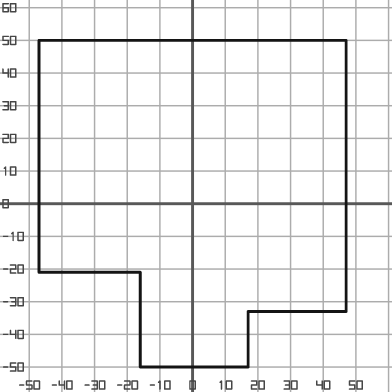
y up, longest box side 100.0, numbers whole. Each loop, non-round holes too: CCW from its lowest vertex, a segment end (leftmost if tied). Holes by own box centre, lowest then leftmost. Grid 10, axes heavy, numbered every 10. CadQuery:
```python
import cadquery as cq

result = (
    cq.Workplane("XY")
    .moveTo(-16.0, -50.0)
    .lineTo(17.0, -50.0)
    .lineTo(17.0, -33.0)
    .lineTo(47.0, -33.0)
    .lineTo(47.0, 50.0)
    .lineTo(-47.0, 50.0)
    .lineTo(-47.0, -21.0)
    .lineTo(-16.0, -21.0)
    .close()
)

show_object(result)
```